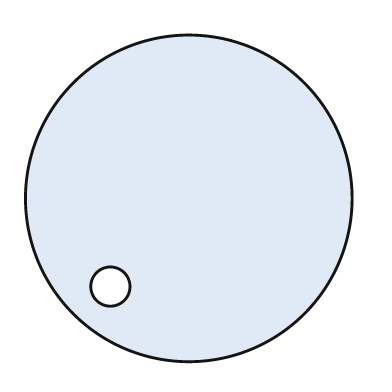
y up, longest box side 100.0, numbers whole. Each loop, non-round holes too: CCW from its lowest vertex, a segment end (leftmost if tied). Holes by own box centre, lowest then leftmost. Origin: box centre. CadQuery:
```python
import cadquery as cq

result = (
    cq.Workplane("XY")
    .moveTo(0.0, 0.0)
    .circle(50.0)
    .moveTo(-24.0, -27.0)
    .circle(6.0)
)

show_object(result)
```